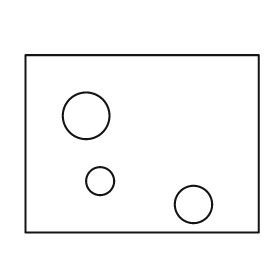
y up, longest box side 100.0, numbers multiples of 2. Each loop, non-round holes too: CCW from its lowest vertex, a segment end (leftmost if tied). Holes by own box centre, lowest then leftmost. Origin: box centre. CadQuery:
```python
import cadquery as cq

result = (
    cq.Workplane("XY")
    .moveTo(-50.0, -38.0)
    .lineTo(50.0, -38.0)
    .lineTo(50.0, 38.0)
    .lineTo(-50.0, 38.0)
    .close()
    .moveTo(22.0, -26.0)
    .circle(8.0)
    .moveTo(-18.0, -16.0)
    .circle(6.0)
    .moveTo(-24.0, 12.0)
    .circle(10.0)
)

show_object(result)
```